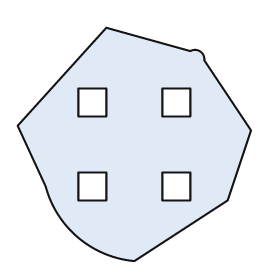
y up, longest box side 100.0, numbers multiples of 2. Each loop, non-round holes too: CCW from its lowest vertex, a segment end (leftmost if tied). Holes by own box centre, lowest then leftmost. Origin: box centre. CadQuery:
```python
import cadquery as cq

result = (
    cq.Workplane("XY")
    .moveTo(0.0, -50.0)
    .lineTo(40.0, -24.0)
    .lineTo(50.0, 6.0)
    .lineTo(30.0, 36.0)
    .threePointArc((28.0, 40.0), (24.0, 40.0))
    .lineTo(-12.0, 50.0)
    .lineTo(-50.0, 8.0)
    .lineTo(-38.0, -18.0)
    .threePointArc((-24.0, -40.0), (0.0, -50.0))
    .close()
    .moveTo(-24.0, -24.0)
    .lineTo(-12.0, -24.0)
    .lineTo(-12.0, -12.0)
    .lineTo(-24.0, -12.0)
    .close()
    .moveTo(12.0, -24.0)
    .lineTo(24.0, -24.0)
    .lineTo(24.0, -12.0)
    .lineTo(12.0, -12.0)
    .close()
    .moveTo(-24.0, 12.0)
    .lineTo(-12.0, 12.0)
    .lineTo(-12.0, 24.0)
    .lineTo(-24.0, 24.0)
    .close()
    .moveTo(12.0, 12.0)
    .lineTo(24.0, 12.0)
    .lineTo(24.0, 24.0)
    .lineTo(12.0, 24.0)
    .close()
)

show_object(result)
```